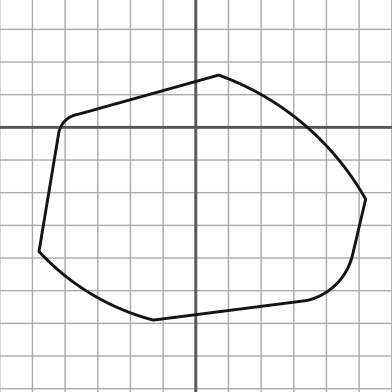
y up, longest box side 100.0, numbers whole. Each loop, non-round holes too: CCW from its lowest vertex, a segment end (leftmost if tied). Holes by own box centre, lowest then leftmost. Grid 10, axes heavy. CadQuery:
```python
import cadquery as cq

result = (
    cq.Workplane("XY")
    .moveTo(-13.0, -59.0)
    .lineTo(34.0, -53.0)
    .threePointArc((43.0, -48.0), (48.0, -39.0))
    .lineTo(52.0, -22.0)
    .threePointArc((33.0, 1.0), (7.0, 16.0))
    .lineTo(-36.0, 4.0)
    .threePointArc((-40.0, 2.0), (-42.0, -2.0))
    .lineTo(-48.0, -38.0)
    .threePointArc((-32.0, -51.0), (-13.0, -59.0))
    .close()
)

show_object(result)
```